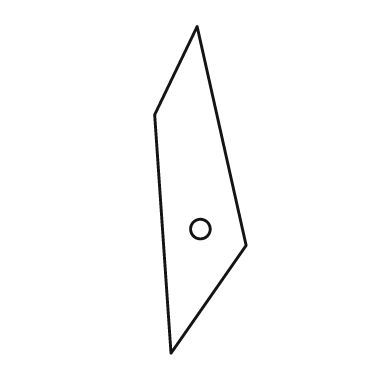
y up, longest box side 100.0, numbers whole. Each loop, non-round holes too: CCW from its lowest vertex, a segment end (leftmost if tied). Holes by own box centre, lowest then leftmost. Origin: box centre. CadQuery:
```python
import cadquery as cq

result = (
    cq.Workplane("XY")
    .moveTo(-9.0, -50.0)
    .lineTo(14.0, -17.0)
    .lineTo(-1.0, 50.0)
    .lineTo(-14.0, 23.0)
    .close()
    .moveTo(0.0, -12.0)
    .circle(3.0)
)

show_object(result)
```